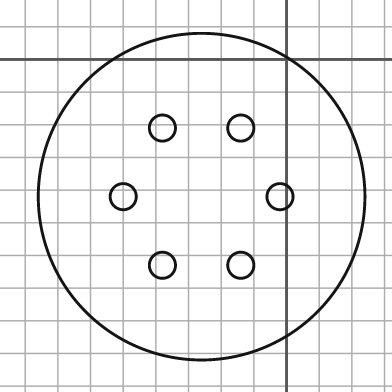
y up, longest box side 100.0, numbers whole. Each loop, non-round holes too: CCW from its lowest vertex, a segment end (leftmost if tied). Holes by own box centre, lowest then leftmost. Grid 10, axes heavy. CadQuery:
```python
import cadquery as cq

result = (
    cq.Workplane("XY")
    .moveTo(-26.0, -42.0)
    .circle(50.0)
    .moveTo(-38.0, -63.0)
    .circle(4.0)
    .moveTo(-14.0, -63.0)
    .circle(4.0)
    .moveTo(-50.0, -42.0)
    .circle(4.0)
    .moveTo(-2.0, -42.0)
    .circle(4.0)
    .moveTo(-38.0, -21.0)
    .circle(4.0)
    .moveTo(-14.0, -21.0)
    .circle(4.0)
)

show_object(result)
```